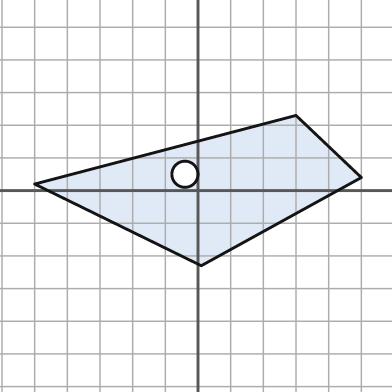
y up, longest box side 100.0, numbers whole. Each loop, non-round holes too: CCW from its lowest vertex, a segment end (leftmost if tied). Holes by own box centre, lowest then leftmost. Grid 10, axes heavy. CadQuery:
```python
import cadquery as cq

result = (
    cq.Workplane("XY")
    .moveTo(1.0, -23.0)
    .lineTo(50.0, 4.0)
    .lineTo(30.0, 23.0)
    .lineTo(-50.0, 2.0)
    .close()
    .moveTo(-4.0, 5.0)
    .circle(4.0)
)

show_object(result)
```